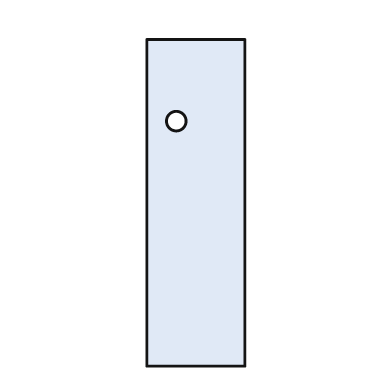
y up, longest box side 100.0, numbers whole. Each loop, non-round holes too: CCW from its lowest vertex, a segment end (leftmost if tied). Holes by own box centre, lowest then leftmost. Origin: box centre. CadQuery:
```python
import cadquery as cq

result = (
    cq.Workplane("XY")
    .moveTo(-15.0, -50.0)
    .lineTo(15.0, -50.0)
    .lineTo(15.0, 50.0)
    .lineTo(-15.0, 50.0)
    .close()
    .moveTo(-6.0, 25.0)
    .circle(3.0)
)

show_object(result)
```